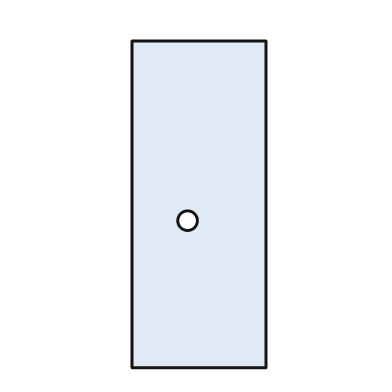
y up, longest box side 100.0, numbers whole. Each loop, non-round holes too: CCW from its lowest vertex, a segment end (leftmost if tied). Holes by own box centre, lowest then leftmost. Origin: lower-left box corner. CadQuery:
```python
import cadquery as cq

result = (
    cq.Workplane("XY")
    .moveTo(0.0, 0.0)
    .lineTo(41.0, 0.0)
    .lineTo(41.0, 100.0)
    .lineTo(0.0, 100.0)
    .close()
    .moveTo(17.0, 45.0)
    .circle(3.0)
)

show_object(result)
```